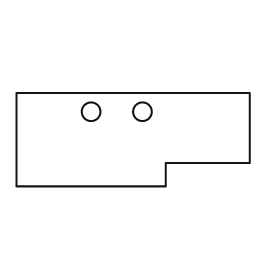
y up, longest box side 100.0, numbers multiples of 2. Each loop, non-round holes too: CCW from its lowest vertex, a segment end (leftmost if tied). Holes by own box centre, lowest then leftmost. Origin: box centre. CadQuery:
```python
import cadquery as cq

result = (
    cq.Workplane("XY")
    .moveTo(-50.0, -20.0)
    .lineTo(14.0, -20.0)
    .lineTo(14.0, -10.0)
    .lineTo(50.0, -10.0)
    .lineTo(50.0, 20.0)
    .lineTo(-50.0, 20.0)
    .close()
    .moveTo(-18.0, 12.0)
    .circle(4.0)
    .moveTo(4.0, 12.0)
    .circle(4.0)
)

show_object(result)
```